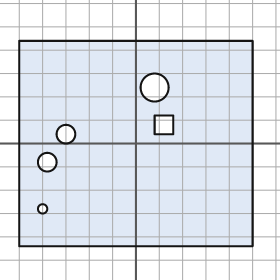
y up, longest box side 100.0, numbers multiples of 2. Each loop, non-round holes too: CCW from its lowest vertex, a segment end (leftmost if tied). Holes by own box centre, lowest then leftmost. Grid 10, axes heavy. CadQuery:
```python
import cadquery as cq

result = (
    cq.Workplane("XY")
    .moveTo(-50.0, -44.0)
    .lineTo(50.0, -44.0)
    .lineTo(50.0, 44.0)
    .lineTo(-50.0, 44.0)
    .close()
    .moveTo(-40.0, -28.0)
    .circle(2.0)
    .moveTo(-38.0, -8.0)
    .circle(4.0)
    .moveTo(-30.0, 4.0)
    .circle(4.0)
    .moveTo(8.0, 4.0)
    .lineTo(16.0, 4.0)
    .lineTo(16.0, 12.0)
    .lineTo(8.0, 12.0)
    .close()
    .moveTo(8.0, 24.0)
    .circle(6.0)
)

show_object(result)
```